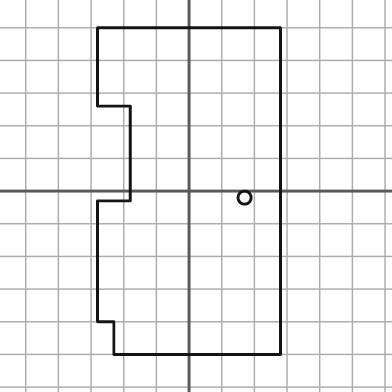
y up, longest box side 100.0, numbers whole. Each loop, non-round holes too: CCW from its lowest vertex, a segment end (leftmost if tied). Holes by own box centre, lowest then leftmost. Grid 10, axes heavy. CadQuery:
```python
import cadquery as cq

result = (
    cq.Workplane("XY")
    .moveTo(-23.0, -50.0)
    .lineTo(28.0, -50.0)
    .lineTo(28.0, 50.0)
    .lineTo(-28.0, 50.0)
    .lineTo(-28.0, 26.0)
    .lineTo(-18.0, 26.0)
    .lineTo(-18.0, -3.0)
    .lineTo(-28.0, -3.0)
    .lineTo(-28.0, -40.0)
    .lineTo(-23.0, -40.0)
    .close()
    .moveTo(17.0, -2.0)
    .circle(2.0)
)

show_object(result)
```